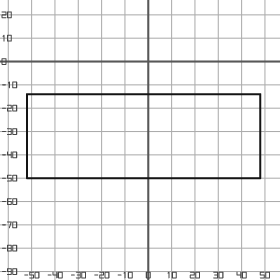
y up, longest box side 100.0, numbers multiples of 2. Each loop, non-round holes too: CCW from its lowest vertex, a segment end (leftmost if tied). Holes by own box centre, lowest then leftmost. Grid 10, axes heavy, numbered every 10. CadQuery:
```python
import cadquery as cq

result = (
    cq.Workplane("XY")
    .moveTo(-52.0, -50.0)
    .lineTo(48.0, -50.0)
    .lineTo(48.0, -14.0)
    .lineTo(-52.0, -14.0)
    .close()
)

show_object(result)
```